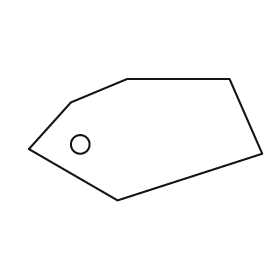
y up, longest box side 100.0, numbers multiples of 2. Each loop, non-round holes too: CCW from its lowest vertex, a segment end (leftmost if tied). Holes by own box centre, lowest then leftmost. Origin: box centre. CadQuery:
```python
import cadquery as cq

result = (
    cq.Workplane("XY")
    .moveTo(-12.0, -26.0)
    .lineTo(50.0, -6.0)
    .lineTo(36.0, 26.0)
    .lineTo(-8.0, 26.0)
    .lineTo(-32.0, 16.0)
    .lineTo(-50.0, -4.0)
    .close()
    .moveTo(-28.0, -2.0)
    .circle(4.0)
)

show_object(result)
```